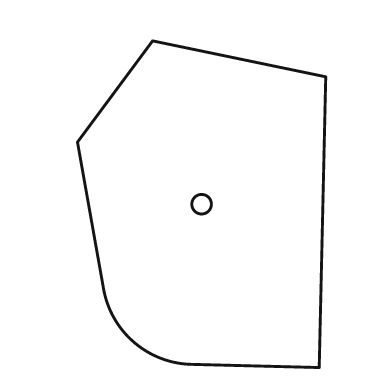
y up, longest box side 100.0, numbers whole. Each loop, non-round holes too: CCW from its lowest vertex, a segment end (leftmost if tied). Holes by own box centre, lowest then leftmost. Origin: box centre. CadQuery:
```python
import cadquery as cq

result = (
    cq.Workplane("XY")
    .moveTo(36.0, -50.0)
    .lineTo(38.0, 39.0)
    .lineTo(-15.0, 50.0)
    .lineTo(-38.0, 19.0)
    .lineTo(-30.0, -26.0)
    .threePointArc((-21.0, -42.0), (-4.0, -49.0))
    .close()
    .moveTo(0.0, 0.0)
    .circle(3.0)
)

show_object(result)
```